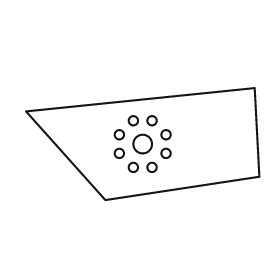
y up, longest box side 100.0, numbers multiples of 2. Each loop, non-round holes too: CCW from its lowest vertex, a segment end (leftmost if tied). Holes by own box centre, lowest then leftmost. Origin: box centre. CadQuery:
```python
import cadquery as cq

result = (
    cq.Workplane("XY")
    .moveTo(-16.0, -24.0)
    .lineTo(50.0, -14.0)
    .lineTo(48.0, 24.0)
    .lineTo(-50.0, 14.0)
    .close()
    .moveTo(-4.0, -10.0)
    .circle(2.0)
    .moveTo(4.0, -10.0)
    .circle(2.0)
    .moveTo(-10.0, -4.0)
    .circle(2.0)
    .moveTo(10.0, -4.0)
    .circle(2.0)
    .moveTo(0.0, 0.0)
    .circle(4.0)
    .moveTo(-10.0, 4.0)
    .circle(2.0)
    .moveTo(10.0, 4.0)
    .circle(2.0)
    .moveTo(-4.0, 10.0)
    .circle(2.0)
    .moveTo(4.0, 10.0)
    .circle(2.0)
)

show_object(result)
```